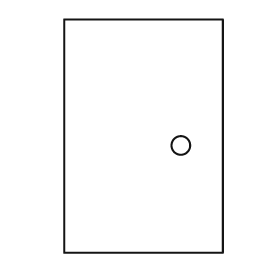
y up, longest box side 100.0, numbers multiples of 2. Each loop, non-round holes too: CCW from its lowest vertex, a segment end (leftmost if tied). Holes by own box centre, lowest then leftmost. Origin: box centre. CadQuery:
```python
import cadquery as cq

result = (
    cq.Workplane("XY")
    .moveTo(-34.0, -50.0)
    .lineTo(34.0, -50.0)
    .lineTo(34.0, 50.0)
    .lineTo(-34.0, 50.0)
    .close()
    .moveTo(16.0, -4.0)
    .circle(4.0)
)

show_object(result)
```